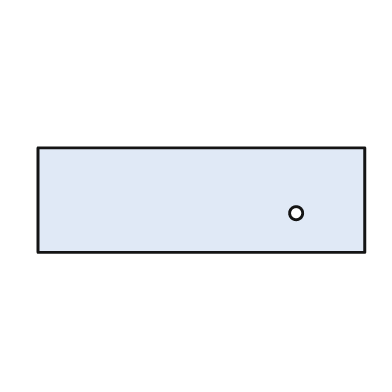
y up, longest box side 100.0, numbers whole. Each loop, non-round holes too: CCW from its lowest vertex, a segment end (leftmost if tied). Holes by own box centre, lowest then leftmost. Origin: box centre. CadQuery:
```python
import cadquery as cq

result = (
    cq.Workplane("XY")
    .moveTo(-50.0, -16.0)
    .lineTo(50.0, -16.0)
    .lineTo(50.0, 16.0)
    .lineTo(-50.0, 16.0)
    .close()
    .moveTo(29.0, -4.0)
    .circle(2.0)
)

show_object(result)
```